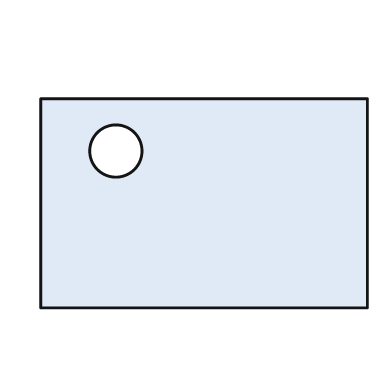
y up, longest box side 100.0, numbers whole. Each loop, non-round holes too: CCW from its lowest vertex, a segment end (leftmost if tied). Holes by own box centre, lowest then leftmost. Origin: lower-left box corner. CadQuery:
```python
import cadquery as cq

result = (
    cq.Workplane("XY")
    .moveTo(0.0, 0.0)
    .lineTo(100.0, 0.0)
    .lineTo(100.0, 64.0)
    .lineTo(0.0, 64.0)
    .close()
    .moveTo(23.0, 48.0)
    .circle(8.0)
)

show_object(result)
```